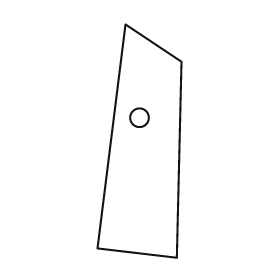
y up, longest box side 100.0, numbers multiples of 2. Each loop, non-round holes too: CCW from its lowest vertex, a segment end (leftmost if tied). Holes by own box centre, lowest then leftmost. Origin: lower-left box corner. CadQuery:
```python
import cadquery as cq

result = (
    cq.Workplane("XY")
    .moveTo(34.0, 0.0)
    .lineTo(36.0, 84.0)
    .lineTo(12.0, 100.0)
    .lineTo(0.0, 4.0)
    .close()
    .moveTo(18.0, 60.0)
    .circle(4.0)
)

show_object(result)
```